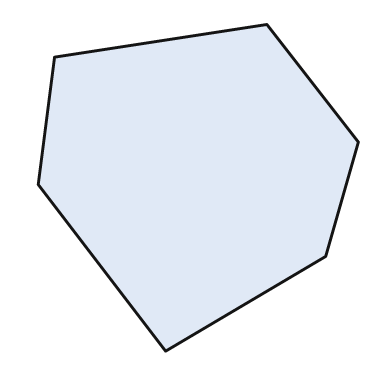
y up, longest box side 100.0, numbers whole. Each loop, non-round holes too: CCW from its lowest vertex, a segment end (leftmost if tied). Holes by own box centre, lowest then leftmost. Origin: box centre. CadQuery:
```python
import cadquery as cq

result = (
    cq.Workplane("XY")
    .moveTo(-10.0, -50.0)
    .lineTo(39.0, -21.0)
    .lineTo(49.0, 14.0)
    .lineTo(21.0, 50.0)
    .lineTo(-44.0, 40.0)
    .lineTo(-49.0, 1.0)
    .close()
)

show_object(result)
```